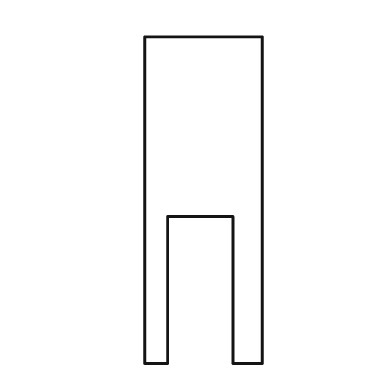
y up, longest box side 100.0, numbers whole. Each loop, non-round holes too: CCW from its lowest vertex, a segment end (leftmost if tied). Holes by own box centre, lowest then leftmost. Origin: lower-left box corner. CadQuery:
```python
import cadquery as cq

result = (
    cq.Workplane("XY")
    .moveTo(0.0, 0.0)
    .lineTo(7.0, 0.0)
    .lineTo(7.0, 45.0)
    .lineTo(27.0, 45.0)
    .lineTo(27.0, 0.0)
    .lineTo(36.0, 0.0)
    .lineTo(36.0, 100.0)
    .lineTo(0.0, 100.0)
    .close()
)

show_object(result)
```